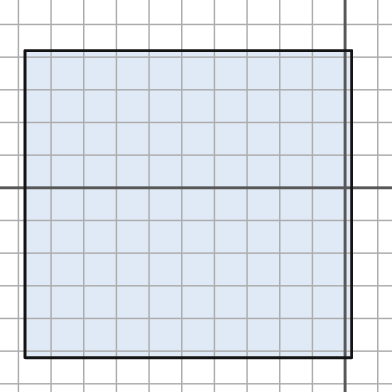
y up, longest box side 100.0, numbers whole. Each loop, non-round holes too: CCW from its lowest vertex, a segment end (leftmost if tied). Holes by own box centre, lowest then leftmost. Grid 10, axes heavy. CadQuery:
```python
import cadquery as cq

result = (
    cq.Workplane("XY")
    .moveTo(-98.0, -52.0)
    .lineTo(2.0, -52.0)
    .lineTo(2.0, 42.0)
    .lineTo(-98.0, 42.0)
    .close()
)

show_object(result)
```